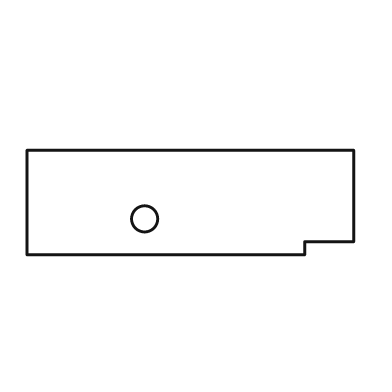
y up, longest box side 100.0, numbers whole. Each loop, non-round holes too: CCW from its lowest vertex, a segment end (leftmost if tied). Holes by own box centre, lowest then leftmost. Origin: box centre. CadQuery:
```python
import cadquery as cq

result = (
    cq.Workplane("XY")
    .moveTo(-50.0, -16.0)
    .lineTo(35.0, -16.0)
    .lineTo(35.0, -12.0)
    .lineTo(50.0, -12.0)
    .lineTo(50.0, 16.0)
    .lineTo(-50.0, 16.0)
    .close()
    .moveTo(-14.0, -5.0)
    .circle(4.0)
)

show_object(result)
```